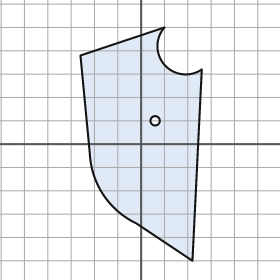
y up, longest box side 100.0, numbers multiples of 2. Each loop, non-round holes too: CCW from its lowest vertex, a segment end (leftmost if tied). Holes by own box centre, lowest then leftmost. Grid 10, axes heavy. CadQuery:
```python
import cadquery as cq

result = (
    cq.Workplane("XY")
    .moveTo(22.0, -50.0)
    .lineTo(26.0, 32.0)
    .threePointArc((10.0, 34.0), (10.0, 50.0))
    .lineTo(-26.0, 38.0)
    .lineTo(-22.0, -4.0)
    .threePointArc((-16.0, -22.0), (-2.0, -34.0))
    .close()
    .moveTo(6.0, 10.0)
    .circle(2.0)
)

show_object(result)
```